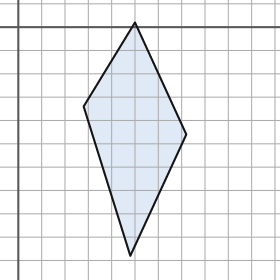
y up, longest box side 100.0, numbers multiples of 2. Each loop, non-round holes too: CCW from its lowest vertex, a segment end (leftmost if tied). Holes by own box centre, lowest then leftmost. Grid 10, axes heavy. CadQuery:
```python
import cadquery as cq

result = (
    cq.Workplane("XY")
    .moveTo(48.0, -98.0)
    .lineTo(72.0, -46.0)
    .lineTo(50.0, 2.0)
    .lineTo(28.0, -34.0)
    .close()
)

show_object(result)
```